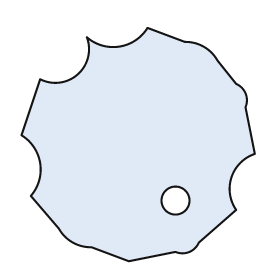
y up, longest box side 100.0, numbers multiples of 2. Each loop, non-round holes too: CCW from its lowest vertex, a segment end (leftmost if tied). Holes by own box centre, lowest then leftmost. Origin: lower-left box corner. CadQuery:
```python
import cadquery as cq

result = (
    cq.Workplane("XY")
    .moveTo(46.0, 0.0)
    .lineTo(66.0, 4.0)
    .threePointArc((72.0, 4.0), (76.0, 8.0))
    .lineTo(92.0, 22.0)
    .threePointArc((90.0, 36.0), (100.0, 46.0))
    .lineTo(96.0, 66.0)
    .threePointArc((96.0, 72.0), (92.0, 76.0))
    .lineTo(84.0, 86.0)
    .threePointArc((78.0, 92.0), (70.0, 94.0))
    .lineTo(54.0, 100.0)
    .threePointArc((42.0, 92.0), (28.0, 96.0))
    .threePointArc((24.0, 80.0), (8.0, 78.0))
    .lineTo(0.0, 54.0)
    .threePointArc((8.0, 42.0), (4.0, 28.0))
    .lineTo(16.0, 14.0)
    .threePointArc((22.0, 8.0), (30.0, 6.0))
    .close()
    .moveTo(66.0, 26.0)
    .circle(6.0)
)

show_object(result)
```